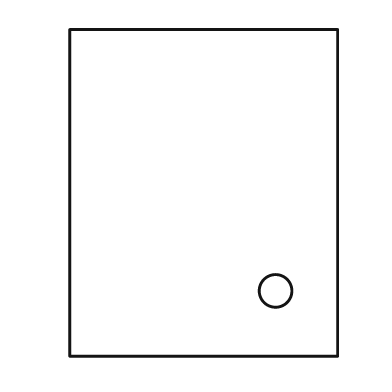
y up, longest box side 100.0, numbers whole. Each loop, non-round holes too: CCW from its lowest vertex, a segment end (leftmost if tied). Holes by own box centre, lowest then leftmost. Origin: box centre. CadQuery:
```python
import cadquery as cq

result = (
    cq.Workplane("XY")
    .moveTo(-41.0, -50.0)
    .lineTo(41.0, -50.0)
    .lineTo(41.0, 50.0)
    .lineTo(-41.0, 50.0)
    .close()
    .moveTo(22.0, -30.0)
    .circle(5.0)
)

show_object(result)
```